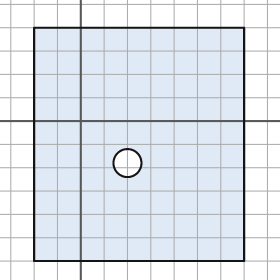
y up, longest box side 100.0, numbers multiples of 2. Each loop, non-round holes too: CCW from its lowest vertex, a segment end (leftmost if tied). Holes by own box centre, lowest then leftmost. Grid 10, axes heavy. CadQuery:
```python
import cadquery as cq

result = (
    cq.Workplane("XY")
    .moveTo(-20.0, -60.0)
    .lineTo(70.0, -60.0)
    .lineTo(70.0, 40.0)
    .lineTo(-20.0, 40.0)
    .close()
    .moveTo(20.0, -18.0)
    .circle(6.0)
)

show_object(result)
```